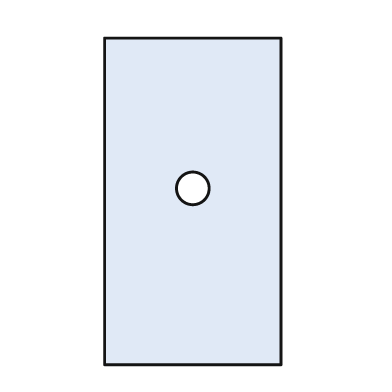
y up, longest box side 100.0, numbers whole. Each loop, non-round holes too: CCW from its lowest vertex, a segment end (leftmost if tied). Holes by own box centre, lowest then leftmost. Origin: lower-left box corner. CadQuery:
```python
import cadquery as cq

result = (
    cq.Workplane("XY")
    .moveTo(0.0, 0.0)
    .lineTo(54.0, 0.0)
    .lineTo(54.0, 100.0)
    .lineTo(0.0, 100.0)
    .close()
    .moveTo(27.0, 54.0)
    .circle(5.0)
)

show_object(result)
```